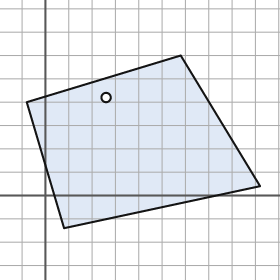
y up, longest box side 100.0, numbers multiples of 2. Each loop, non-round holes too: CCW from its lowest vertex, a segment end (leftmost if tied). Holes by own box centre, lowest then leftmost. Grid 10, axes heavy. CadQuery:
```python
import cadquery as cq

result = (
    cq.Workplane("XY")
    .moveTo(8.0, -14.0)
    .lineTo(92.0, 4.0)
    .lineTo(58.0, 60.0)
    .lineTo(-8.0, 40.0)
    .close()
    .moveTo(26.0, 42.0)
    .circle(2.0)
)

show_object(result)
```